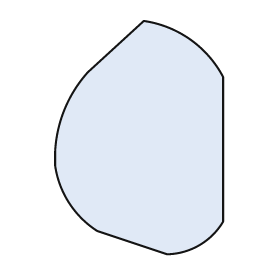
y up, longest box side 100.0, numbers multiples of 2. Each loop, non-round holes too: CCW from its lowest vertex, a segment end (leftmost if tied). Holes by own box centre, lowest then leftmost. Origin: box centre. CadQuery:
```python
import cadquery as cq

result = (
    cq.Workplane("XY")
    .moveTo(12.0, -50.0)
    .threePointArc((26.0, -46.0), (36.0, -36.0))
    .lineTo(36.0, 26.0)
    .threePointArc((22.0, 42.0), (2.0, 50.0))
    .lineTo(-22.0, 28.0)
    .threePointArc((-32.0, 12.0), (-36.0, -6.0))
    .lineTo(-36.0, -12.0)
    .threePointArc((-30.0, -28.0), (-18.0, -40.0))
    .close()
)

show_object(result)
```